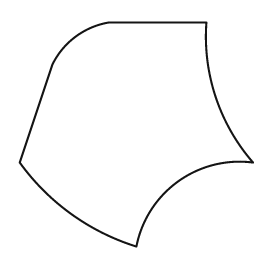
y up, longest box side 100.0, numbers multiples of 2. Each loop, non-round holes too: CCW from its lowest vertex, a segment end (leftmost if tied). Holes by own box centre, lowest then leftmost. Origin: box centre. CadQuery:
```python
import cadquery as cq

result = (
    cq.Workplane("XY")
    .moveTo(0.0, -48.0)
    .threePointArc((18.0, -20.0), (50.0, -12.0))
    .threePointArc((34.0, 16.0), (30.0, 48.0))
    .lineTo(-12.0, 48.0)
    .threePointArc((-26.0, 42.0), (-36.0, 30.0))
    .lineTo(-50.0, -12.0)
    .threePointArc((-28.0, -34.0), (0.0, -48.0))
    .close()
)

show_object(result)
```